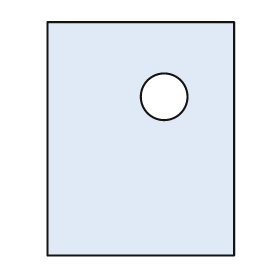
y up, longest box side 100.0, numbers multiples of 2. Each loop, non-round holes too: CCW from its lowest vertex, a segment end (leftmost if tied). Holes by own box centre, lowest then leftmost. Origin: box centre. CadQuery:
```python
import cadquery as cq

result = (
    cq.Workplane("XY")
    .moveTo(-40.0, -50.0)
    .lineTo(40.0, -50.0)
    .lineTo(40.0, 50.0)
    .lineTo(-40.0, 50.0)
    .close()
    .moveTo(10.0, 18.0)
    .circle(10.0)
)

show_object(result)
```